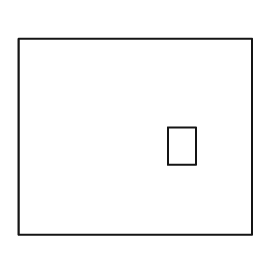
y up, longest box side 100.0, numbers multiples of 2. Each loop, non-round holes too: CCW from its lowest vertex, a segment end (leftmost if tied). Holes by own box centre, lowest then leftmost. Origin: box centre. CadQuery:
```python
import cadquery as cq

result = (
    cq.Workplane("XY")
    .moveTo(-50.0, -42.0)
    .lineTo(50.0, -42.0)
    .lineTo(50.0, 42.0)
    .lineTo(-50.0, 42.0)
    .close()
    .moveTo(14.0, -12.0)
    .lineTo(26.0, -12.0)
    .lineTo(26.0, 4.0)
    .lineTo(14.0, 4.0)
    .close()
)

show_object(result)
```